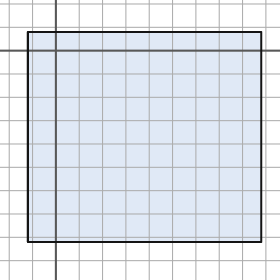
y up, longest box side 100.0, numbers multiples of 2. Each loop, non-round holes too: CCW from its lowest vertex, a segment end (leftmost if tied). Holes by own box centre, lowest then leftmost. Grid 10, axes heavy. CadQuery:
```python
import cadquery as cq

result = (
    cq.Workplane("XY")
    .moveTo(-12.0, -82.0)
    .lineTo(88.0, -82.0)
    .lineTo(88.0, 8.0)
    .lineTo(-12.0, 8.0)
    .close()
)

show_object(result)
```